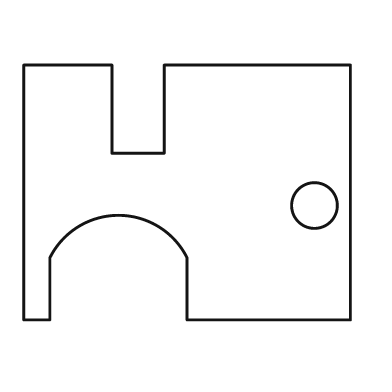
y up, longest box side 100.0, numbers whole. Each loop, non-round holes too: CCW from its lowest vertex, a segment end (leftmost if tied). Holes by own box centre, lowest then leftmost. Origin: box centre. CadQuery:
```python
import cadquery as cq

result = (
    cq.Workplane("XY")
    .moveTo(-50.0, -39.0)
    .lineTo(-42.0, -39.0)
    .lineTo(-42.0, -20.0)
    .threePointArc((-21.0, -7.0), (0.0, -20.0))
    .lineTo(0.0, -39.0)
    .lineTo(50.0, -39.0)
    .lineTo(50.0, 39.0)
    .lineTo(-7.0, 39.0)
    .lineTo(-7.0, 12.0)
    .lineTo(-23.0, 12.0)
    .lineTo(-23.0, 39.0)
    .lineTo(-50.0, 39.0)
    .close()
    .moveTo(39.0, -4.0)
    .circle(7.0)
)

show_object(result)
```